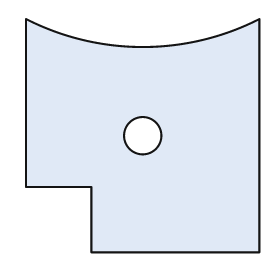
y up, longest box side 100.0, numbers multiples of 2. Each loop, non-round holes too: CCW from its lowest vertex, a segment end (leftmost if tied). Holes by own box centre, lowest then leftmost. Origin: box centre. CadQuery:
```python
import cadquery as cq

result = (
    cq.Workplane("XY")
    .moveTo(-22.0, -50.0)
    .lineTo(50.0, -50.0)
    .lineTo(50.0, 50.0)
    .threePointArc((0.0, 38.0), (-50.0, 50.0))
    .lineTo(-50.0, -22.0)
    .lineTo(-22.0, -22.0)
    .close()
    .moveTo(0.0, 0.0)
    .circle(8.0)
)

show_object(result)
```